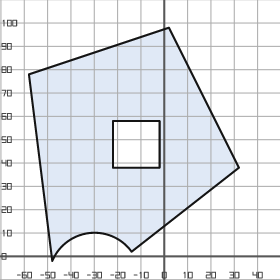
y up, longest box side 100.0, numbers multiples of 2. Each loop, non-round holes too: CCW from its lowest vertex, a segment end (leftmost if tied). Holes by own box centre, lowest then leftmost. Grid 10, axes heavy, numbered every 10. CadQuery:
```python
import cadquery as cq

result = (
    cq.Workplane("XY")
    .moveTo(-48.0, -2.0)
    .threePointArc((-32.0, 10.0), (-14.0, 2.0))
    .lineTo(32.0, 38.0)
    .lineTo(2.0, 98.0)
    .lineTo(-58.0, 78.0)
    .close()
    .moveTo(-22.0, 38.0)
    .lineTo(-2.0, 38.0)
    .lineTo(-2.0, 58.0)
    .lineTo(-22.0, 58.0)
    .close()
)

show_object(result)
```